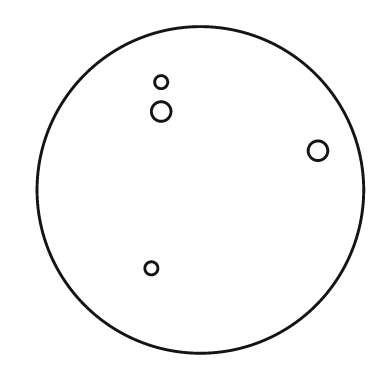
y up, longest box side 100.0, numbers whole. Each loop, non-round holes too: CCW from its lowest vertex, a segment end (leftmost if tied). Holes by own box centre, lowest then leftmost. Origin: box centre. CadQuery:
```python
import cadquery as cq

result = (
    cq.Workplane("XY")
    .moveTo(0.0, 0.0)
    .circle(50.0)
    .moveTo(-15.0, -24.0)
    .circle(2.0)
    .moveTo(36.0, 12.0)
    .circle(3.0)
    .moveTo(-12.0, 24.0)
    .circle(3.0)
    .moveTo(-12.0, 33.0)
    .circle(2.0)
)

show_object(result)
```